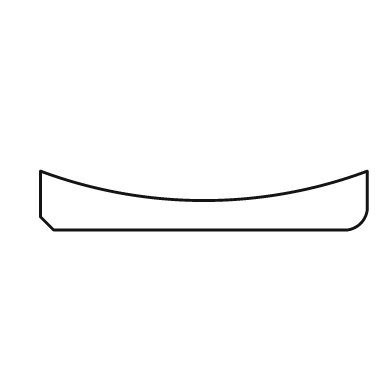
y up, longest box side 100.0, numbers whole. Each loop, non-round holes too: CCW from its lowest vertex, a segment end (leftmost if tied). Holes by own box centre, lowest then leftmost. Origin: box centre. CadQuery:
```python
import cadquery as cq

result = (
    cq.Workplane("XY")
    .moveTo(-46.0, -9.0)
    .lineTo(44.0, -9.0)
    .threePointArc((48.0, -7.0), (50.0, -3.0))
    .lineTo(50.0, 9.0)
    .threePointArc((0.0, 0.0), (-50.0, 9.0))
    .lineTo(-50.0, -5.0)
    .close()
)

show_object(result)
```